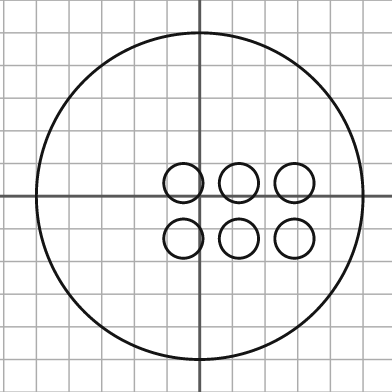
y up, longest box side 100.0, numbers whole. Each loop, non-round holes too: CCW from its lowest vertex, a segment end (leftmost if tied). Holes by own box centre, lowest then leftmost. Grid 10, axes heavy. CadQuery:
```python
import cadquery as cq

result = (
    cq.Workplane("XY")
    .moveTo(0.0, 0.0)
    .circle(50.0)
    .moveTo(-5.0, -13.0)
    .circle(6.0)
    .moveTo(12.0, -13.0)
    .circle(6.0)
    .moveTo(29.0, -13.0)
    .circle(6.0)
    .moveTo(-5.0, 4.0)
    .circle(6.0)
    .moveTo(12.0, 4.0)
    .circle(6.0)
    .moveTo(29.0, 4.0)
    .circle(6.0)
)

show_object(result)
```